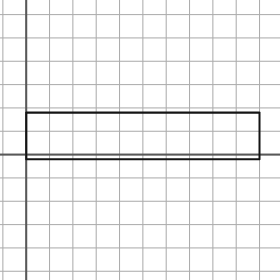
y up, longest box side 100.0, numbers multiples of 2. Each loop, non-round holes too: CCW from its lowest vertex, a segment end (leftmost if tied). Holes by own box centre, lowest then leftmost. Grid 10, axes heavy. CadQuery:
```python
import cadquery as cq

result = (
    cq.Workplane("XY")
    .moveTo(0.0, -2.0)
    .lineTo(100.0, -2.0)
    .lineTo(100.0, 18.0)
    .lineTo(0.0, 18.0)
    .close()
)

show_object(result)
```